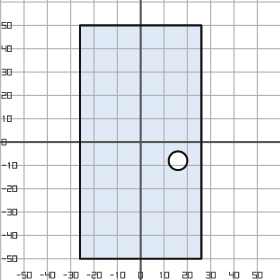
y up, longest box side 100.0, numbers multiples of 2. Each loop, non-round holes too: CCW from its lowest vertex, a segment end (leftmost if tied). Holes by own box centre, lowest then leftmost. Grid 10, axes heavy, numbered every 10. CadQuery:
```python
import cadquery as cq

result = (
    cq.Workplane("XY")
    .moveTo(-26.0, -50.0)
    .lineTo(26.0, -50.0)
    .lineTo(26.0, 50.0)
    .lineTo(-26.0, 50.0)
    .close()
    .moveTo(16.0, -8.0)
    .circle(4.0)
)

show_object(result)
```